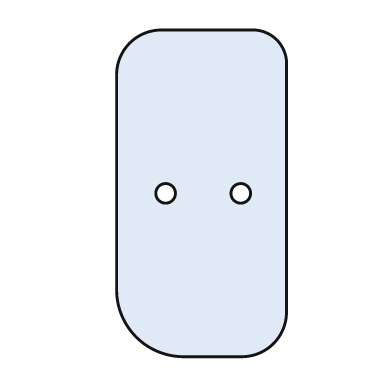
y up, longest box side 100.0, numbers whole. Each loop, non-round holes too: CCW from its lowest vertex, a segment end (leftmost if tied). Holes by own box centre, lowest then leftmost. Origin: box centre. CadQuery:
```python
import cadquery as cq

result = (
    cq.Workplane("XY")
    .moveTo(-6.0, -50.0)
    .lineTo(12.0, -50.0)
    .threePointArc((22.0, -46.0), (26.0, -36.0))
    .lineTo(26.0, 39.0)
    .threePointArc((23.0, 47.0), (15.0, 50.0))
    .lineTo(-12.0, 50.0)
    .threePointArc((-22.0, 46.0), (-26.0, 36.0))
    .lineTo(-26.0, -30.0)
    .threePointArc((-20.0, -44.0), (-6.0, -50.0))
    .close()
    .moveTo(-11.0, 0.0)
    .circle(3.0)
    .moveTo(12.0, 0.0)
    .circle(3.0)
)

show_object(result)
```